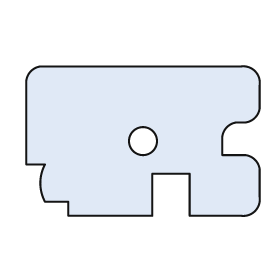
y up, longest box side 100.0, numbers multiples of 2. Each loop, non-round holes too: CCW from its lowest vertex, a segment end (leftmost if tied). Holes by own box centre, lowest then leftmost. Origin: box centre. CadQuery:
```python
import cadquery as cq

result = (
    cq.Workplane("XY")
    .moveTo(-32.0, -32.0)
    .lineTo(4.0, -32.0)
    .lineTo(4.0, -14.0)
    .lineTo(20.0, -14.0)
    .lineTo(20.0, -32.0)
    .lineTo(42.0, -32.0)
    .threePointArc((48.0, -30.0), (50.0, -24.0))
    .lineTo(50.0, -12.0)
    .threePointArc((48.0, -8.0), (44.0, -6.0))
    .lineTo(34.0, -6.0)
    .lineTo(34.0, 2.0)
    .threePointArc((36.0, 6.0), (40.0, 8.0))
    .lineTo(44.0, 8.0)
    .threePointArc((48.0, 10.0), (50.0, 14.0))
    .lineTo(50.0, 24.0)
    .threePointArc((48.0, 30.0), (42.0, 32.0))
    .lineTo(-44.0, 32.0)
    .threePointArc((-48.0, 30.0), (-50.0, 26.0))
    .lineTo(-50.0, -10.0)
    .lineTo(-42.0, -10.0)
    .threePointArc((-44.0, -18.0), (-42.0, -26.0))
    .lineTo(-32.0, -26.0)
    .close()
    .moveTo(0.0, 0.0)
    .circle(6.0)
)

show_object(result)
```